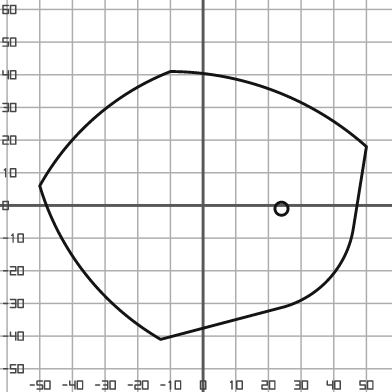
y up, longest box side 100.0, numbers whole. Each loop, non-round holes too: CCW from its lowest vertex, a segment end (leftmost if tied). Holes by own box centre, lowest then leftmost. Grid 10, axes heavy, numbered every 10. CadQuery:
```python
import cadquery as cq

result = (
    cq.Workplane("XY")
    .moveTo(-13.0, -41.0)
    .lineTo(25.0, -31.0)
    .threePointArc((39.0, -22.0), (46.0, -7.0))
    .lineTo(50.0, 18.0)
    .threePointArc((22.0, 35.0), (-10.0, 41.0))
    .threePointArc((-33.0, 27.0), (-50.0, 6.0))
    .threePointArc((-36.0, -21.0), (-13.0, -41.0))
    .close()
    .moveTo(24.0, -1.0)
    .circle(2.0)
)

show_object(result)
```